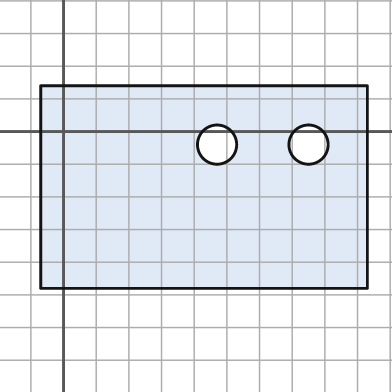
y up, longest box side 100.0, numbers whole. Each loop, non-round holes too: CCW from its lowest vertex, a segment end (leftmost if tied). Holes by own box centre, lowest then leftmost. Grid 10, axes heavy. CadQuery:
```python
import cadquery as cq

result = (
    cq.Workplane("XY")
    .moveTo(-7.0, -48.0)
    .lineTo(93.0, -48.0)
    .lineTo(93.0, 14.0)
    .lineTo(-7.0, 14.0)
    .close()
    .moveTo(47.0, -4.0)
    .circle(6.0)
    .moveTo(75.0, -4.0)
    .circle(6.0)
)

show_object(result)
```